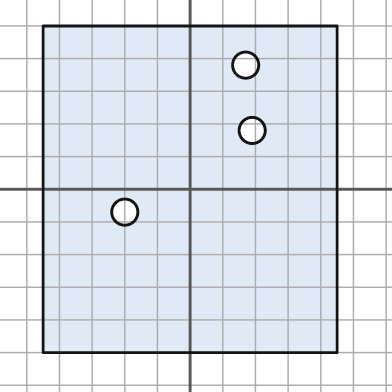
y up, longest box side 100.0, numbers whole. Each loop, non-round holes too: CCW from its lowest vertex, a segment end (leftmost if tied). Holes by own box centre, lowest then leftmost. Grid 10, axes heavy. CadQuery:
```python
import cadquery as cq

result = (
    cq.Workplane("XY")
    .moveTo(-45.0, -50.0)
    .lineTo(45.0, -50.0)
    .lineTo(45.0, 50.0)
    .lineTo(-45.0, 50.0)
    .close()
    .moveTo(-20.0, -7.0)
    .circle(4.0)
    .moveTo(19.0, 18.0)
    .circle(4.0)
    .moveTo(17.0, 38.0)
    .circle(4.0)
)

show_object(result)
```